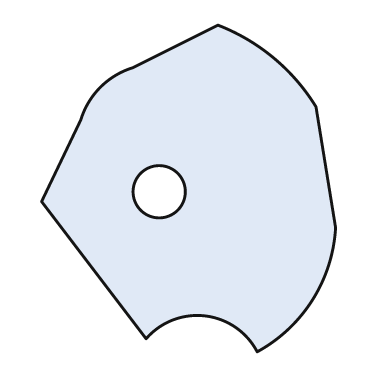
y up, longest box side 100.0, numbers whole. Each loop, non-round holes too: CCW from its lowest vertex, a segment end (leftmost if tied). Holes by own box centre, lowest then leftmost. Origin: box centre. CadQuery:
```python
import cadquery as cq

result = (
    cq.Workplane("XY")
    .moveTo(21.0, -50.0)
    .threePointArc((38.0, -34.0), (45.0, -12.0))
    .lineTo(39.0, 25.0)
    .threePointArc((26.0, 40.0), (9.0, 50.0))
    .lineTo(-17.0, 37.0)
    .threePointArc((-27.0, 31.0), (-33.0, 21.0))
    .lineTo(-45.0, -4.0)
    .lineTo(-13.0, -46.0)
    .threePointArc((5.0, -39.0), (21.0, -50.0))
    .close()
    .moveTo(-9.0, -1.0)
    .circle(8.0)
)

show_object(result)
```